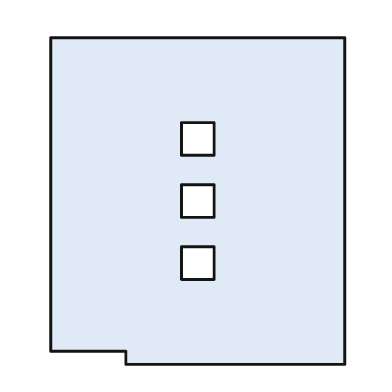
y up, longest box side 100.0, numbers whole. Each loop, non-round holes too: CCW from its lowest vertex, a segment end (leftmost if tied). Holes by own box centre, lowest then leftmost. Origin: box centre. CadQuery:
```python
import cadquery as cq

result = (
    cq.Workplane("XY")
    .moveTo(-22.0, -50.0)
    .lineTo(45.0, -50.0)
    .lineTo(45.0, 50.0)
    .lineTo(-45.0, 50.0)
    .lineTo(-45.0, -46.0)
    .lineTo(-22.0, -46.0)
    .close()
    .moveTo(-5.0, -24.0)
    .lineTo(5.0, -24.0)
    .lineTo(5.0, -14.0)
    .lineTo(-5.0, -14.0)
    .close()
    .moveTo(-5.0, -5.0)
    .lineTo(5.0, -5.0)
    .lineTo(5.0, 5.0)
    .lineTo(-5.0, 5.0)
    .close()
    .moveTo(-5.0, 14.0)
    .lineTo(5.0, 14.0)
    .lineTo(5.0, 24.0)
    .lineTo(-5.0, 24.0)
    .close()
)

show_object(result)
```